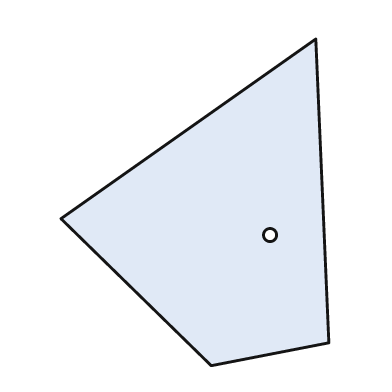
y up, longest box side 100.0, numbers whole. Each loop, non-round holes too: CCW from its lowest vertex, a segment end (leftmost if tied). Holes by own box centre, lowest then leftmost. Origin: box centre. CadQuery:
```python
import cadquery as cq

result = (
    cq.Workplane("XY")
    .moveTo(5.0, -50.0)
    .lineTo(41.0, -43.0)
    .lineTo(37.0, 50.0)
    .lineTo(-41.0, -5.0)
    .close()
    .moveTo(23.0, -10.0)
    .circle(2.0)
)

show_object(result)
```